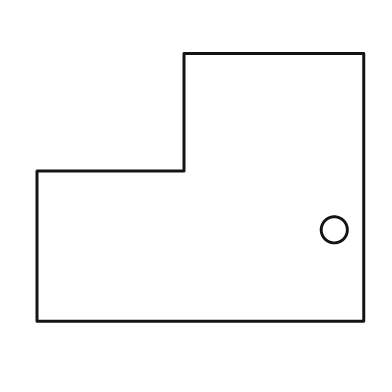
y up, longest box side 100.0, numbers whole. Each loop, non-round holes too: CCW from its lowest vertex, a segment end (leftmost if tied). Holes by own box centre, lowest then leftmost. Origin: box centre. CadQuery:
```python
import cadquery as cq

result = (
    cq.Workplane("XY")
    .moveTo(-50.0, -41.0)
    .lineTo(50.0, -41.0)
    .lineTo(50.0, 41.0)
    .lineTo(-5.0, 41.0)
    .lineTo(-5.0, 5.0)
    .lineTo(-50.0, 5.0)
    .close()
    .moveTo(41.0, -13.0)
    .circle(4.0)
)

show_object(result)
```